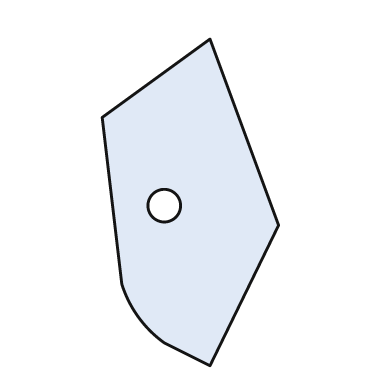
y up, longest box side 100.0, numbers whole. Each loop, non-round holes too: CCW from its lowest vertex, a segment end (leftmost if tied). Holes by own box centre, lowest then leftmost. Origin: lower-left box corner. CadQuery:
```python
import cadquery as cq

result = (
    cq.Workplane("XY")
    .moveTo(33.0, 0.0)
    .lineTo(54.0, 43.0)
    .lineTo(33.0, 100.0)
    .lineTo(0.0, 76.0)
    .lineTo(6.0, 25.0)
    .threePointArc((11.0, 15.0), (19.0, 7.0))
    .close()
    .moveTo(19.0, 49.0)
    .circle(5.0)
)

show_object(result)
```